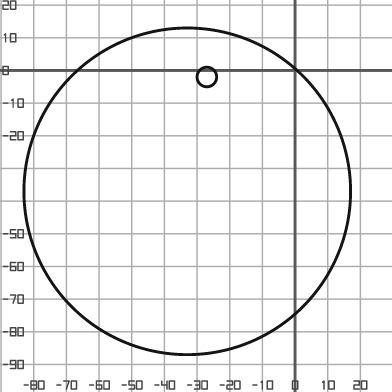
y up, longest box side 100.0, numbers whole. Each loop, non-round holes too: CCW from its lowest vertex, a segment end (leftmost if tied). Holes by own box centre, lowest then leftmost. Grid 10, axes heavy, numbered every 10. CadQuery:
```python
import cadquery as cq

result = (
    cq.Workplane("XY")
    .moveTo(-33.0, -37.0)
    .circle(50.0)
    .moveTo(-27.0, -2.0)
    .circle(3.0)
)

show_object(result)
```